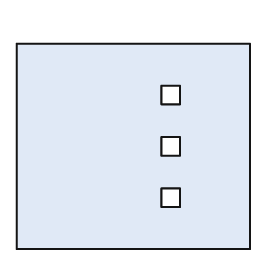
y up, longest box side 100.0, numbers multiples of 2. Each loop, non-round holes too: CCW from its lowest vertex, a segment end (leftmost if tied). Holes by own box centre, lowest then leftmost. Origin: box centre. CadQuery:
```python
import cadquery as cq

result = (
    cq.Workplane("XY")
    .moveTo(-50.0, -44.0)
    .lineTo(50.0, -44.0)
    .lineTo(50.0, 44.0)
    .lineTo(-50.0, 44.0)
    .close()
    .moveTo(12.0, -26.0)
    .lineTo(20.0, -26.0)
    .lineTo(20.0, -18.0)
    .lineTo(12.0, -18.0)
    .close()
    .moveTo(12.0, -4.0)
    .lineTo(20.0, -4.0)
    .lineTo(20.0, 4.0)
    .lineTo(12.0, 4.0)
    .close()
    .moveTo(12.0, 18.0)
    .lineTo(20.0, 18.0)
    .lineTo(20.0, 26.0)
    .lineTo(12.0, 26.0)
    .close()
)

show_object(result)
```